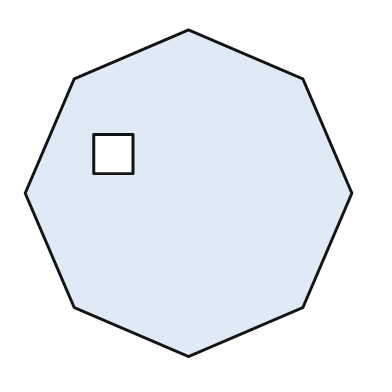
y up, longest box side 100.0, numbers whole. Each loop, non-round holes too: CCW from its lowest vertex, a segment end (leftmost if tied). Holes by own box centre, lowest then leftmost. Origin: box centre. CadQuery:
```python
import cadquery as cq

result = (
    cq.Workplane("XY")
    .moveTo(0.0, -50.0)
    .lineTo(35.0, -35.0)
    .lineTo(50.0, 0.0)
    .lineTo(35.0, 35.0)
    .lineTo(0.0, 50.0)
    .lineTo(-35.0, 35.0)
    .lineTo(-50.0, 0.0)
    .lineTo(-35.0, -35.0)
    .close()
    .moveTo(-29.0, 6.0)
    .lineTo(-17.0, 6.0)
    .lineTo(-17.0, 18.0)
    .lineTo(-29.0, 18.0)
    .close()
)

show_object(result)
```